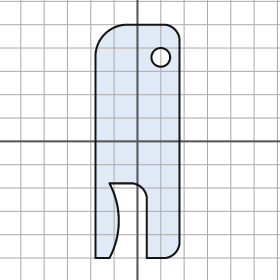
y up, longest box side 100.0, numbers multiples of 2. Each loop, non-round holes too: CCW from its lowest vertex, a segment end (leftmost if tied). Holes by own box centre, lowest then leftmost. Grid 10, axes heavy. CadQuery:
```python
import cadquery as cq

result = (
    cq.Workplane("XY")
    .moveTo(-18.0, -50.0)
    .lineTo(-12.0, -50.0)
    .threePointArc((-8.0, -34.0), (-12.0, -18.0))
    .lineTo(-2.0, -18.0)
    .threePointArc((2.0, -20.0), (4.0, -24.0))
    .lineTo(4.0, -50.0)
    .lineTo(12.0, -50.0)
    .threePointArc((16.0, -48.0), (18.0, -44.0))
    .lineTo(18.0, 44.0)
    .threePointArc((16.0, 48.0), (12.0, 50.0))
    .lineTo(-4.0, 50.0)
    .threePointArc((-14.0, 46.0), (-18.0, 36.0))
    .close()
    .moveTo(10.0, 36.0)
    .circle(4.0)
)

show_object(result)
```